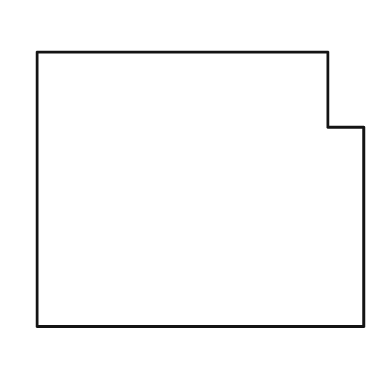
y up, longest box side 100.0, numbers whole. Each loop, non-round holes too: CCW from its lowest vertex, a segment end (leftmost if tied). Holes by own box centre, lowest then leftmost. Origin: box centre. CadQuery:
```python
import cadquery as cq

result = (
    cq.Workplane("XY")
    .moveTo(-50.0, -42.0)
    .lineTo(50.0, -42.0)
    .lineTo(50.0, 19.0)
    .lineTo(39.0, 19.0)
    .lineTo(39.0, 42.0)
    .lineTo(-50.0, 42.0)
    .close()
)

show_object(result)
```